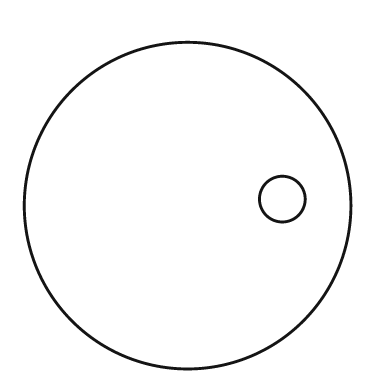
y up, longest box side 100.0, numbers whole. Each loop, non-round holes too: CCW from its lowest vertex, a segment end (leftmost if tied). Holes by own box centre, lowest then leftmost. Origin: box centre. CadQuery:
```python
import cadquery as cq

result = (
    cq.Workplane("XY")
    .moveTo(0.0, 0.0)
    .circle(50.0)
    .moveTo(29.0, 2.0)
    .circle(7.0)
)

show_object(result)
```